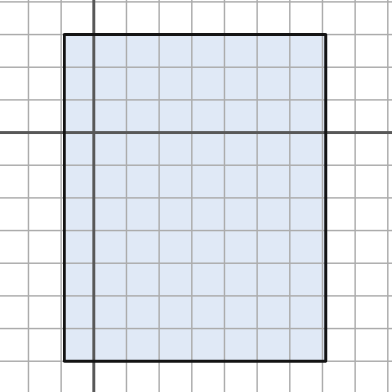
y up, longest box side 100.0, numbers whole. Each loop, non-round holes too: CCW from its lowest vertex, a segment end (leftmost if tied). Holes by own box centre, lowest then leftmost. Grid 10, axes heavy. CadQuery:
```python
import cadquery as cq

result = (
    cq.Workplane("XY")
    .moveTo(-9.0, -70.0)
    .lineTo(71.0, -70.0)
    .lineTo(71.0, 30.0)
    .lineTo(-9.0, 30.0)
    .close()
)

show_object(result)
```